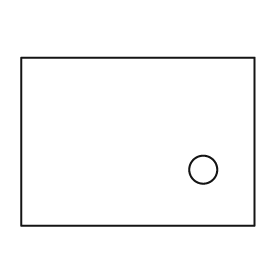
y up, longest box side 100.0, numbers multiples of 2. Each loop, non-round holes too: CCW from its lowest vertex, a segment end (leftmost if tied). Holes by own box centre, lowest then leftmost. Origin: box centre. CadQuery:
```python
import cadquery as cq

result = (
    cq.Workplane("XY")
    .moveTo(-50.0, -36.0)
    .lineTo(50.0, -36.0)
    .lineTo(50.0, 36.0)
    .lineTo(-50.0, 36.0)
    .close()
    .moveTo(28.0, -12.0)
    .circle(6.0)
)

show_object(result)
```